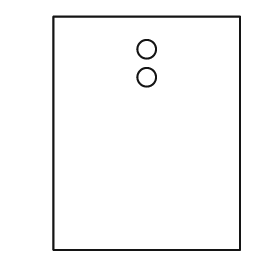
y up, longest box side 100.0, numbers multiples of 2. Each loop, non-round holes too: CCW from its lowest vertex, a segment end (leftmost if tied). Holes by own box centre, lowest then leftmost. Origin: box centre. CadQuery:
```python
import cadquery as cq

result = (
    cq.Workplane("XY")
    .moveTo(-40.0, -50.0)
    .lineTo(40.0, -50.0)
    .lineTo(40.0, 50.0)
    .lineTo(-40.0, 50.0)
    .close()
    .moveTo(0.0, 24.0)
    .circle(4.0)
    .moveTo(0.0, 36.0)
    .circle(4.0)
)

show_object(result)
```